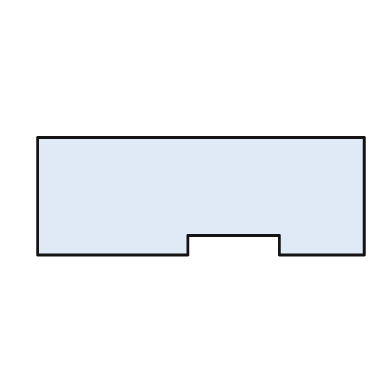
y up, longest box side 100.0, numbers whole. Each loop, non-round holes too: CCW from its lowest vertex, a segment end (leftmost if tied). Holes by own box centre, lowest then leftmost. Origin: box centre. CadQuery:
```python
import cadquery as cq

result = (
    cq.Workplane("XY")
    .moveTo(-50.0, -18.0)
    .lineTo(-4.0, -18.0)
    .lineTo(-4.0, -12.0)
    .lineTo(24.0, -12.0)
    .lineTo(24.0, -18.0)
    .lineTo(50.0, -18.0)
    .lineTo(50.0, 18.0)
    .lineTo(-50.0, 18.0)
    .close()
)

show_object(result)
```